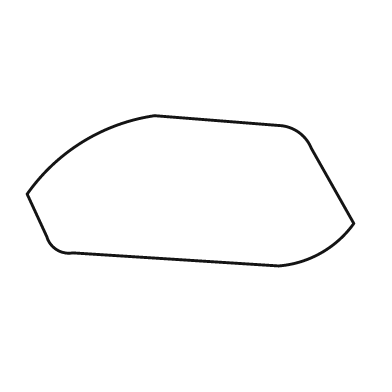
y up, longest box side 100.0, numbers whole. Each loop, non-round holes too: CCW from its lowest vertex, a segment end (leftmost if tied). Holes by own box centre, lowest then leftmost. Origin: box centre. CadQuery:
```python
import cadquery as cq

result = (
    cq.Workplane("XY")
    .moveTo(27.0, -23.0)
    .threePointArc((40.0, -19.0), (50.0, -10.0))
    .lineTo(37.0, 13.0)
    .threePointArc((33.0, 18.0), (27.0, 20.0))
    .lineTo(-11.0, 23.0)
    .threePointArc((-33.0, 15.0), (-50.0, -1.0))
    .lineTo(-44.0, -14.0)
    .threePointArc((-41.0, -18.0), (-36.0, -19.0))
    .close()
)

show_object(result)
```